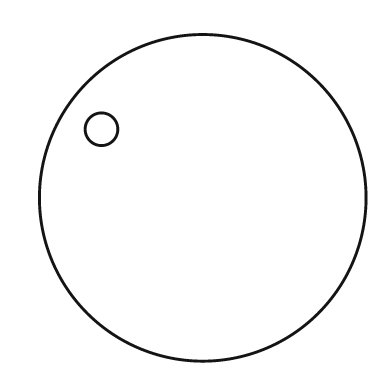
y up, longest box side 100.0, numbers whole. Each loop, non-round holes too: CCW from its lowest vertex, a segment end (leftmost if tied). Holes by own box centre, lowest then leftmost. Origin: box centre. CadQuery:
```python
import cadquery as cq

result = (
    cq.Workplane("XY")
    .moveTo(0.0, 0.0)
    .circle(50.0)
    .moveTo(-31.0, 21.0)
    .circle(5.0)
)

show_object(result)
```